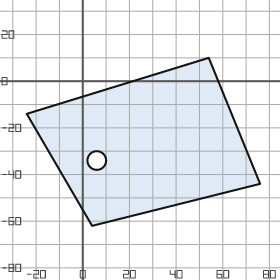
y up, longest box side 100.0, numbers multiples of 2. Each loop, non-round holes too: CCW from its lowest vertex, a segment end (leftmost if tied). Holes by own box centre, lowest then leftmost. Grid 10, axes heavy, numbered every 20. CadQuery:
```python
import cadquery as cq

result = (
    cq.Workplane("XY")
    .moveTo(4.0, -62.0)
    .lineTo(76.0, -44.0)
    .lineTo(54.0, 10.0)
    .lineTo(-24.0, -14.0)
    .close()
    .moveTo(6.0, -34.0)
    .circle(4.0)
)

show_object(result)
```